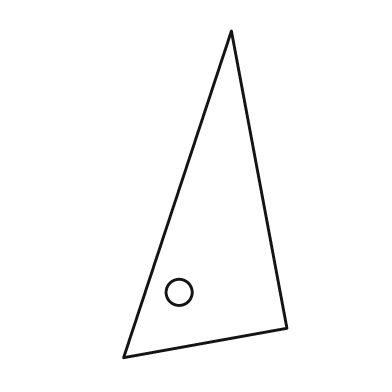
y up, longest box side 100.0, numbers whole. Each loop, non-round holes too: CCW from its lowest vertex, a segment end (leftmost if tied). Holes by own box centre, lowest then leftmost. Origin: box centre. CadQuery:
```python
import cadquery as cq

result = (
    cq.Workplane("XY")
    .moveTo(-25.0, -50.0)
    .lineTo(25.0, -41.0)
    .lineTo(8.0, 50.0)
    .close()
    .moveTo(-8.0, -30.0)
    .circle(4.0)
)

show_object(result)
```